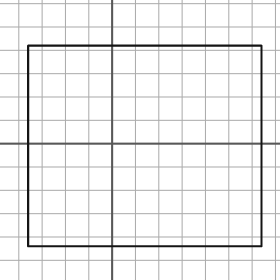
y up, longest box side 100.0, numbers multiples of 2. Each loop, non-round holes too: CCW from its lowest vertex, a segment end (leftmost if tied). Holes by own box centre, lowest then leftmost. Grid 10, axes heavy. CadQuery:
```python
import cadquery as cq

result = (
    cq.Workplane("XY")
    .moveTo(-36.0, -44.0)
    .lineTo(64.0, -44.0)
    .lineTo(64.0, 42.0)
    .lineTo(-36.0, 42.0)
    .close()
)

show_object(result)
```